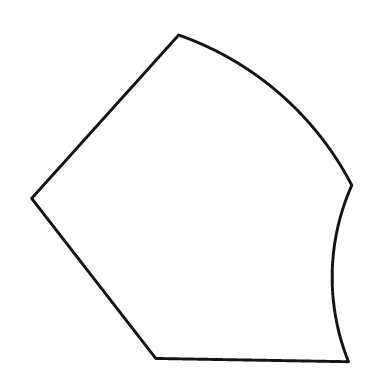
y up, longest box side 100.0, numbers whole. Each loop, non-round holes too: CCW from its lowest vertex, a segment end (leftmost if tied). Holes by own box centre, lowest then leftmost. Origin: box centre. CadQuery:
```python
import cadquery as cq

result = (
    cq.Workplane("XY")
    .moveTo(48.0, -50.0)
    .threePointArc((43.0, -23.0), (49.0, 4.0))
    .threePointArc((27.0, 32.0), (-4.0, 50.0))
    .lineTo(-49.0, 0.0)
    .lineTo(-11.0, -49.0)
    .close()
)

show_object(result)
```